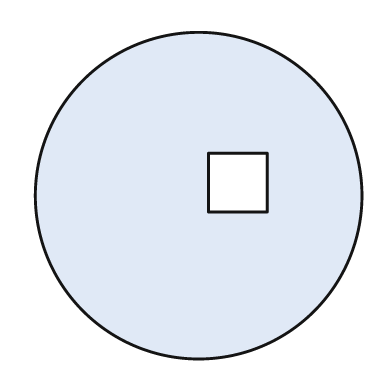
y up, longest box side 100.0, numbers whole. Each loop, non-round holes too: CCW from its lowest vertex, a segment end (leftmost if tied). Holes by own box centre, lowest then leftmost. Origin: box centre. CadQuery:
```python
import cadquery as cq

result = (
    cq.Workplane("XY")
    .moveTo(0.0, 0.0)
    .circle(50.0)
    .moveTo(3.0, -5.0)
    .lineTo(21.0, -5.0)
    .lineTo(21.0, 13.0)
    .lineTo(3.0, 13.0)
    .close()
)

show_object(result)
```